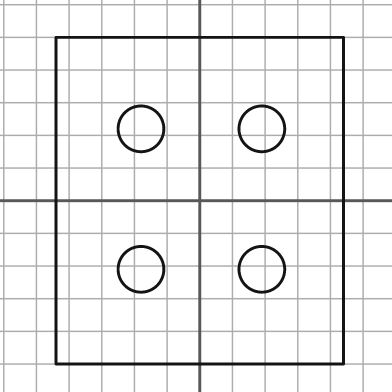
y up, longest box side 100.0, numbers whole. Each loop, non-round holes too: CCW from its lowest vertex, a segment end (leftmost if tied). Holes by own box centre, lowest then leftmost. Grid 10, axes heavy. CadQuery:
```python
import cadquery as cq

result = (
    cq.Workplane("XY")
    .moveTo(-44.0, -50.0)
    .lineTo(44.0, -50.0)
    .lineTo(44.0, 50.0)
    .lineTo(-44.0, 50.0)
    .close()
    .moveTo(-18.0, -21.0)
    .circle(7.0)
    .moveTo(19.0, -21.0)
    .circle(7.0)
    .moveTo(-18.0, 22.0)
    .circle(7.0)
    .moveTo(19.0, 22.0)
    .circle(7.0)
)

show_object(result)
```